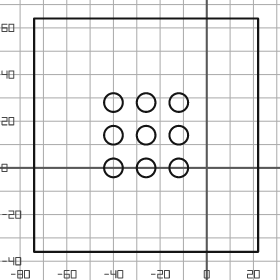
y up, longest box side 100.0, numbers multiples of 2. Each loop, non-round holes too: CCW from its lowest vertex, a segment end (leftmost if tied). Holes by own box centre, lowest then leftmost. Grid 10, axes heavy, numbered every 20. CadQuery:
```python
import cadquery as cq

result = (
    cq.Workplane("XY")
    .moveTo(-74.0, -36.0)
    .lineTo(22.0, -36.0)
    .lineTo(22.0, 64.0)
    .lineTo(-74.0, 64.0)
    .close()
    .moveTo(-40.0, 0.0)
    .circle(4.0)
    .moveTo(-26.0, 0.0)
    .circle(4.0)
    .moveTo(-12.0, 0.0)
    .circle(4.0)
    .moveTo(-40.0, 14.0)
    .circle(4.0)
    .moveTo(-26.0, 14.0)
    .circle(4.0)
    .moveTo(-12.0, 14.0)
    .circle(4.0)
    .moveTo(-40.0, 28.0)
    .circle(4.0)
    .moveTo(-26.0, 28.0)
    .circle(4.0)
    .moveTo(-12.0, 28.0)
    .circle(4.0)
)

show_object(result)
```